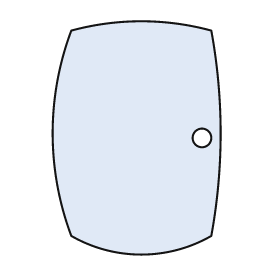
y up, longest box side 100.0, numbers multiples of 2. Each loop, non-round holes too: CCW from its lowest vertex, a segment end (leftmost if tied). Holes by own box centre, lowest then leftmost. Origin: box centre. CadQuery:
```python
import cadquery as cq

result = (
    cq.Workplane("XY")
    .moveTo(-28.0, -42.0)
    .threePointArc((2.0, -50.0), (32.0, -42.0))
    .threePointArc((36.0, 2.0), (32.0, 46.0))
    .threePointArc((2.0, 50.0), (-28.0, 46.0))
    .threePointArc((-36.0, 2.0), (-28.0, -42.0))
    .close()
    .moveTo(28.0, 0.0)
    .circle(4.0)
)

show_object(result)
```